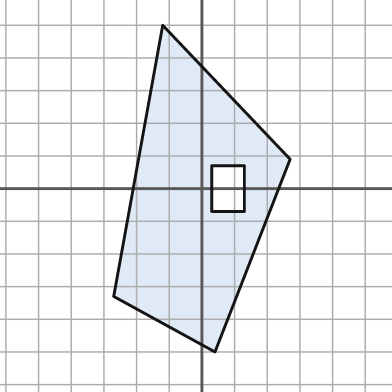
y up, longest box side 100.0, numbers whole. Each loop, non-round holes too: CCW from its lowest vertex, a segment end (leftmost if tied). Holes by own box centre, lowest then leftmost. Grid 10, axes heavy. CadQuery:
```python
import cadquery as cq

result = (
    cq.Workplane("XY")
    .moveTo(4.0, -50.0)
    .lineTo(27.0, 9.0)
    .lineTo(-12.0, 50.0)
    .lineTo(-27.0, -33.0)
    .close()
    .moveTo(3.0, -7.0)
    .lineTo(13.0, -7.0)
    .lineTo(13.0, 7.0)
    .lineTo(3.0, 7.0)
    .close()
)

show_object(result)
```